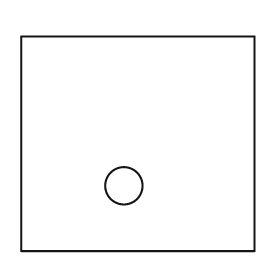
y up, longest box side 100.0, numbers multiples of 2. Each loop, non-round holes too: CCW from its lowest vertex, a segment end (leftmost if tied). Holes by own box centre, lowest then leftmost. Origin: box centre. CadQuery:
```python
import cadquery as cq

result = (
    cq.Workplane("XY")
    .moveTo(-50.0, -46.0)
    .lineTo(50.0, -46.0)
    .lineTo(50.0, 46.0)
    .lineTo(-50.0, 46.0)
    .close()
    .moveTo(-6.0, -18.0)
    .circle(8.0)
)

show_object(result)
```